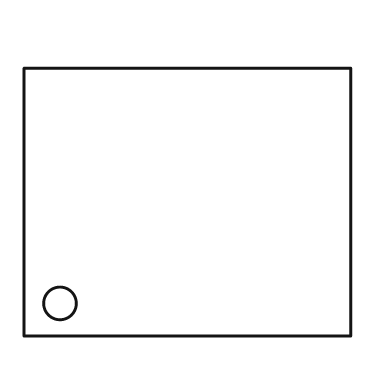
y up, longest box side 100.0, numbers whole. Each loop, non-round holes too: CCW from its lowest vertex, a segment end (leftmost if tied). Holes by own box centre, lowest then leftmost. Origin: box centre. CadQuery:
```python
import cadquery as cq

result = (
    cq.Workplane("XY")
    .moveTo(-50.0, -41.0)
    .lineTo(50.0, -41.0)
    .lineTo(50.0, 41.0)
    .lineTo(-50.0, 41.0)
    .close()
    .moveTo(-39.0, -31.0)
    .circle(5.0)
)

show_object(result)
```